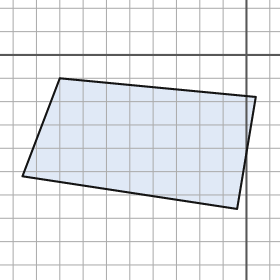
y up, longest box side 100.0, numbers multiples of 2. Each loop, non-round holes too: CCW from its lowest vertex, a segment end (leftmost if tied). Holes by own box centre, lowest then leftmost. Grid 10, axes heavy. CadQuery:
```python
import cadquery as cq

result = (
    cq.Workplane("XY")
    .moveTo(-4.0, -66.0)
    .lineTo(4.0, -18.0)
    .lineTo(-80.0, -10.0)
    .lineTo(-96.0, -52.0)
    .close()
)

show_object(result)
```